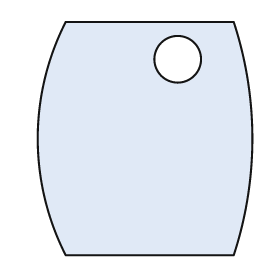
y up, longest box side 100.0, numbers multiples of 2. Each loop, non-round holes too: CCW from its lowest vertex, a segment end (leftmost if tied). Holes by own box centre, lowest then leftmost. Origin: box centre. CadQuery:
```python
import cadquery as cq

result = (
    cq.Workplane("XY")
    .moveTo(-34.0, -50.0)
    .lineTo(38.0, -50.0)
    .threePointArc((46.0, 0.0), (38.0, 50.0))
    .lineTo(-34.0, 50.0)
    .threePointArc((-46.0, 0.0), (-34.0, -50.0))
    .close()
    .moveTo(14.0, 34.0)
    .circle(10.0)
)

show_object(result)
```